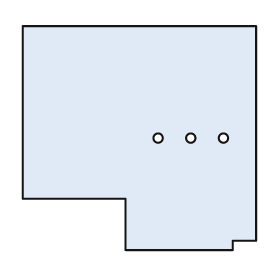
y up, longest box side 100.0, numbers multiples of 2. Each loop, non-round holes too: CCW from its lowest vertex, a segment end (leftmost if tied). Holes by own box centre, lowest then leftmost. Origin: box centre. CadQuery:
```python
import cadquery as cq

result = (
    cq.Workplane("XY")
    .moveTo(-6.0, -48.0)
    .lineTo(40.0, -48.0)
    .lineTo(40.0, -44.0)
    .lineTo(50.0, -44.0)
    .lineTo(50.0, 48.0)
    .lineTo(-50.0, 48.0)
    .lineTo(-50.0, -26.0)
    .lineTo(-6.0, -26.0)
    .close()
    .moveTo(8.0, 0.0)
    .circle(2.0)
    .moveTo(22.0, 0.0)
    .circle(2.0)
    .moveTo(36.0, 0.0)
    .circle(2.0)
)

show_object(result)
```